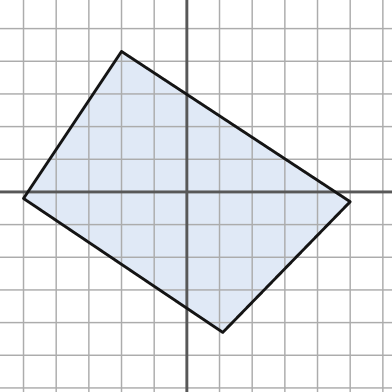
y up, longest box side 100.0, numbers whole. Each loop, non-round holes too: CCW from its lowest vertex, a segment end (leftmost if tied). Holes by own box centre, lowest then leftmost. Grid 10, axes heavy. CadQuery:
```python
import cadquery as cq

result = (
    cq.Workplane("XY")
    .moveTo(11.0, -43.0)
    .lineTo(50.0, -3.0)
    .lineTo(-20.0, 43.0)
    .lineTo(-50.0, -2.0)
    .close()
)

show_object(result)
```